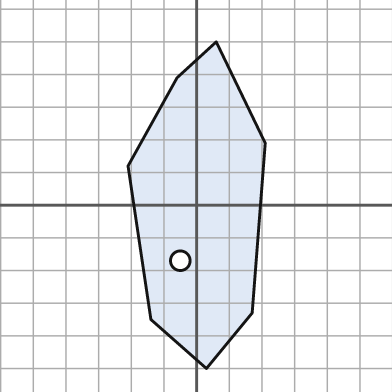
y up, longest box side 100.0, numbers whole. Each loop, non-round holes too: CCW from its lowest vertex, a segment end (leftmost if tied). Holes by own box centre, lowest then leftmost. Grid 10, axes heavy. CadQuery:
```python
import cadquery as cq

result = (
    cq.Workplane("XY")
    .moveTo(3.0, -50.0)
    .lineTo(17.0, -33.0)
    .lineTo(21.0, 19.0)
    .lineTo(6.0, 50.0)
    .lineTo(-6.0, 39.0)
    .lineTo(-21.0, 12.0)
    .lineTo(-14.0, -35.0)
    .close()
    .moveTo(-5.0, -17.0)
    .circle(3.0)
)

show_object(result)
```